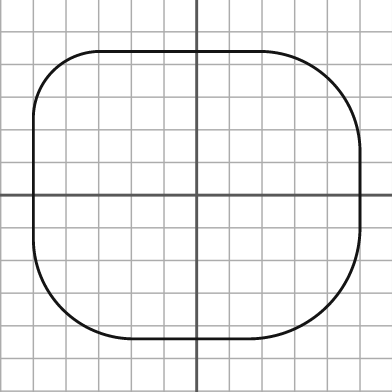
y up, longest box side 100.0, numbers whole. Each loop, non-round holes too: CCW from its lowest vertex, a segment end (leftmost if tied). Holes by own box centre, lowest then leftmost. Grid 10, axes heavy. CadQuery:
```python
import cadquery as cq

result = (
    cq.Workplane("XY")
    .moveTo(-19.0, -44.0)
    .lineTo(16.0, -44.0)
    .threePointArc((40.0, -34.0), (50.0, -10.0))
    .lineTo(50.0, 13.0)
    .threePointArc((41.0, 35.0), (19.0, 44.0))
    .lineTo(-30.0, 44.0)
    .threePointArc((-44.0, 38.0), (-50.0, 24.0))
    .lineTo(-50.0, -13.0)
    .threePointArc((-41.0, -35.0), (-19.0, -44.0))
    .close()
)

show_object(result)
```